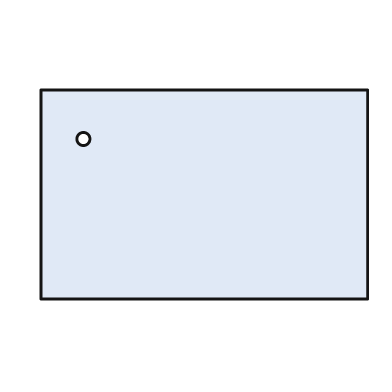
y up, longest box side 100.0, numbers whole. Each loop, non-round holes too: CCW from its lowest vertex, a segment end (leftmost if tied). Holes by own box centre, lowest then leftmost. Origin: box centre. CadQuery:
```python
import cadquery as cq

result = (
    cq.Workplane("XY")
    .moveTo(-50.0, -32.0)
    .lineTo(50.0, -32.0)
    .lineTo(50.0, 32.0)
    .lineTo(-50.0, 32.0)
    .close()
    .moveTo(-37.0, 17.0)
    .circle(2.0)
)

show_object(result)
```